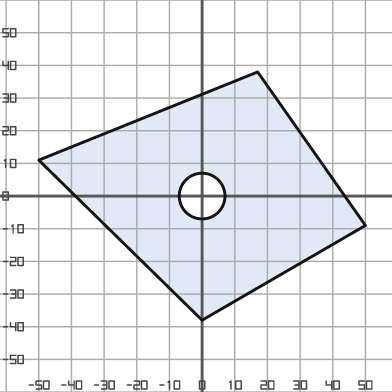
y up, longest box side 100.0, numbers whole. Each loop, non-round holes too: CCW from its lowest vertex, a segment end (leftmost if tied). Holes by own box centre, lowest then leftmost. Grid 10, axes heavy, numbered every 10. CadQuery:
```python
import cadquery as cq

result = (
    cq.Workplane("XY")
    .moveTo(0.0, -38.0)
    .lineTo(50.0, -9.0)
    .lineTo(17.0, 38.0)
    .lineTo(-50.0, 11.0)
    .close()
    .moveTo(0.0, 0.0)
    .circle(7.0)
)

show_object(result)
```